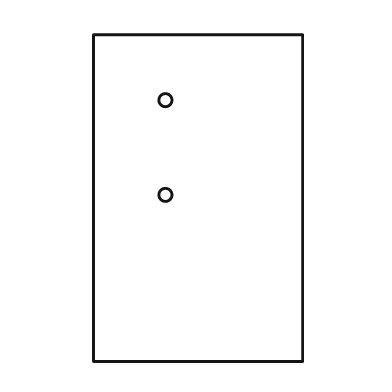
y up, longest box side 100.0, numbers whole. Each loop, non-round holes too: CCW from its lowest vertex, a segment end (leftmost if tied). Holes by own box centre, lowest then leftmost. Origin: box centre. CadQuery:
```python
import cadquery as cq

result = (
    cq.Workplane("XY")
    .moveTo(-32.0, -50.0)
    .lineTo(32.0, -50.0)
    .lineTo(32.0, 50.0)
    .lineTo(-32.0, 50.0)
    .close()
    .moveTo(-10.0, 1.0)
    .circle(2.0)
    .moveTo(-10.0, 30.0)
    .circle(2.0)
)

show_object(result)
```